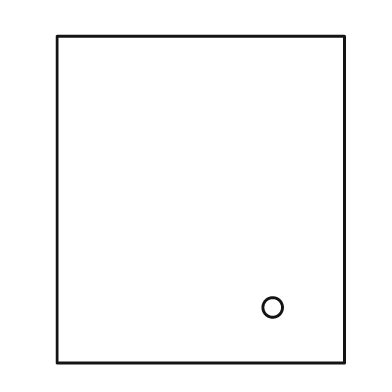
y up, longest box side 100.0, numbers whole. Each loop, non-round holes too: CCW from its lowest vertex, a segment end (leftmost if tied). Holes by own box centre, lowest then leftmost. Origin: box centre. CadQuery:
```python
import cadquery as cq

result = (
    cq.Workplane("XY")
    .moveTo(-44.0, -50.0)
    .lineTo(44.0, -50.0)
    .lineTo(44.0, 50.0)
    .lineTo(-44.0, 50.0)
    .close()
    .moveTo(22.0, -33.0)
    .circle(3.0)
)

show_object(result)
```